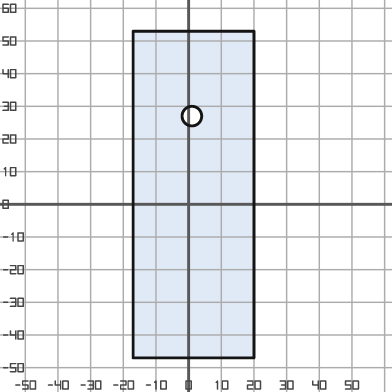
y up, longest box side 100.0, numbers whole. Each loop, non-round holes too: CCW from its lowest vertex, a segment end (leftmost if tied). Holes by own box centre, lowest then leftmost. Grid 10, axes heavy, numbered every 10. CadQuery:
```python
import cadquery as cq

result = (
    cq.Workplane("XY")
    .moveTo(-17.0, -47.0)
    .lineTo(20.0, -47.0)
    .lineTo(20.0, 53.0)
    .lineTo(-17.0, 53.0)
    .close()
    .moveTo(1.0, 27.0)
    .circle(3.0)
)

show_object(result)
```